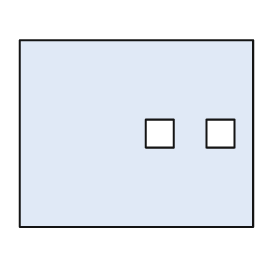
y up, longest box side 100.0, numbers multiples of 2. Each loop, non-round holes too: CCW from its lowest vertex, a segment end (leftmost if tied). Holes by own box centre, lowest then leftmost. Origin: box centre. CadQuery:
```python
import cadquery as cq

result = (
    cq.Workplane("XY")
    .moveTo(-50.0, -40.0)
    .lineTo(50.0, -40.0)
    .lineTo(50.0, 40.0)
    .lineTo(-50.0, 40.0)
    .close()
    .moveTo(4.0, -6.0)
    .lineTo(16.0, -6.0)
    .lineTo(16.0, 6.0)
    .lineTo(4.0, 6.0)
    .close()
    .moveTo(30.0, -6.0)
    .lineTo(42.0, -6.0)
    .lineTo(42.0, 6.0)
    .lineTo(30.0, 6.0)
    .close()
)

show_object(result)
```